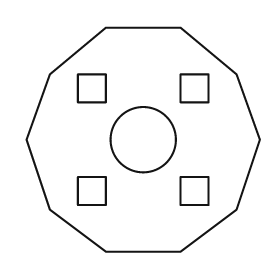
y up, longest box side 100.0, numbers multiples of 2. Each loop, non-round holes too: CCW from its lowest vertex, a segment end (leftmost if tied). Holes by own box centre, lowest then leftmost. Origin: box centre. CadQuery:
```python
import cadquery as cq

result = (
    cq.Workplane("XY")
    .moveTo(-16.0, -48.0)
    .lineTo(16.0, -48.0)
    .lineTo(40.0, -30.0)
    .lineTo(50.0, 0.0)
    .lineTo(40.0, 28.0)
    .lineTo(16.0, 48.0)
    .lineTo(-16.0, 48.0)
    .lineTo(-40.0, 28.0)
    .lineTo(-50.0, 0.0)
    .lineTo(-40.0, -30.0)
    .close()
    .moveTo(-28.0, -28.0)
    .lineTo(-16.0, -28.0)
    .lineTo(-16.0, -16.0)
    .lineTo(-28.0, -16.0)
    .close()
    .moveTo(16.0, -28.0)
    .lineTo(28.0, -28.0)
    .lineTo(28.0, -16.0)
    .lineTo(16.0, -16.0)
    .close()
    .moveTo(0.0, 0.0)
    .circle(14.0)
    .moveTo(-28.0, 16.0)
    .lineTo(-16.0, 16.0)
    .lineTo(-16.0, 28.0)
    .lineTo(-28.0, 28.0)
    .close()
    .moveTo(16.0, 16.0)
    .lineTo(28.0, 16.0)
    .lineTo(28.0, 28.0)
    .lineTo(16.0, 28.0)
    .close()
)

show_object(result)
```